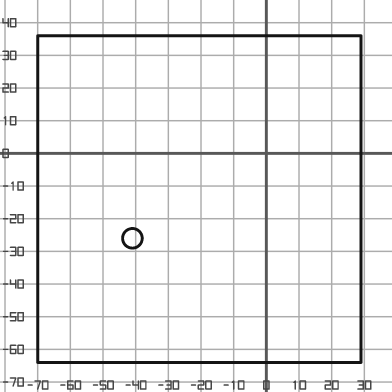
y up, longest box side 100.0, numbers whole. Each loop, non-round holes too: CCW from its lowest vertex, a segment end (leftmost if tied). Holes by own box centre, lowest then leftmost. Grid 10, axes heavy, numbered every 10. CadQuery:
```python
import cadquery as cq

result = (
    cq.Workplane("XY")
    .moveTo(-70.0, -64.0)
    .lineTo(29.0, -64.0)
    .lineTo(29.0, 36.0)
    .lineTo(-70.0, 36.0)
    .close()
    .moveTo(-41.0, -26.0)
    .circle(3.0)
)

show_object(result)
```